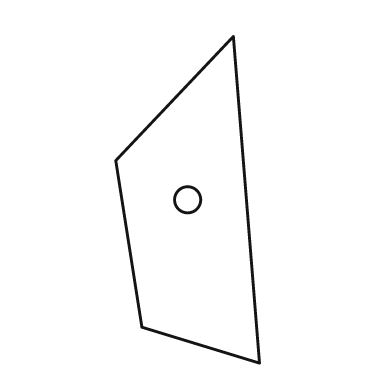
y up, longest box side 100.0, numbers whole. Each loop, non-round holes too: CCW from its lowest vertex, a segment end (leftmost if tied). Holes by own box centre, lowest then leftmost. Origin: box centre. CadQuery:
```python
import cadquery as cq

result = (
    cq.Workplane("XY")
    .moveTo(22.0, -50.0)
    .lineTo(14.0, 50.0)
    .lineTo(-22.0, 12.0)
    .lineTo(-14.0, -39.0)
    .close()
    .moveTo(0.0, 0.0)
    .circle(4.0)
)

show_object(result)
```